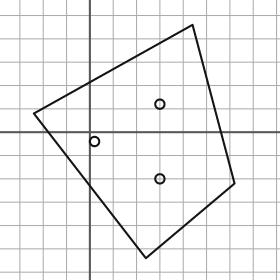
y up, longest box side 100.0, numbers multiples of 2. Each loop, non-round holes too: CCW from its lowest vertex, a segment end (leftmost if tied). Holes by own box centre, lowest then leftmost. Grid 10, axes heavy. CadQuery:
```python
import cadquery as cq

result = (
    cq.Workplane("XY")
    .moveTo(24.0, -54.0)
    .lineTo(62.0, -22.0)
    .lineTo(44.0, 46.0)
    .lineTo(-24.0, 8.0)
    .close()
    .moveTo(30.0, -20.0)
    .circle(2.0)
    .moveTo(2.0, -4.0)
    .circle(2.0)
    .moveTo(30.0, 12.0)
    .circle(2.0)
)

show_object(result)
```